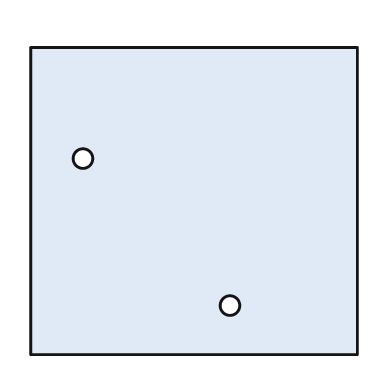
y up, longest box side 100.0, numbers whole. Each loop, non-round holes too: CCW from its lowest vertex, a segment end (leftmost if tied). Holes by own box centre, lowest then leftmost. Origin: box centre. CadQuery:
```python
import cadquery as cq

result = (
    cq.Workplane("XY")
    .moveTo(-50.0, -47.0)
    .lineTo(50.0, -47.0)
    .lineTo(50.0, 47.0)
    .lineTo(-50.0, 47.0)
    .close()
    .moveTo(11.0, -32.0)
    .circle(3.0)
    .moveTo(-34.0, 13.0)
    .circle(3.0)
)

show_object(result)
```